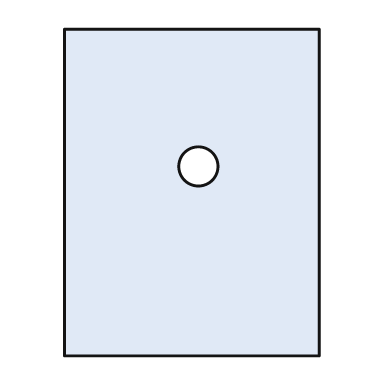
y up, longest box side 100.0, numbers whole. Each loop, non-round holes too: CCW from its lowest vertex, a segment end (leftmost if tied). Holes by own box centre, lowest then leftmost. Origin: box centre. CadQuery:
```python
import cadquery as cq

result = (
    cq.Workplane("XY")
    .moveTo(-39.0, -50.0)
    .lineTo(39.0, -50.0)
    .lineTo(39.0, 50.0)
    .lineTo(-39.0, 50.0)
    .close()
    .moveTo(2.0, 8.0)
    .circle(6.0)
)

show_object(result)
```